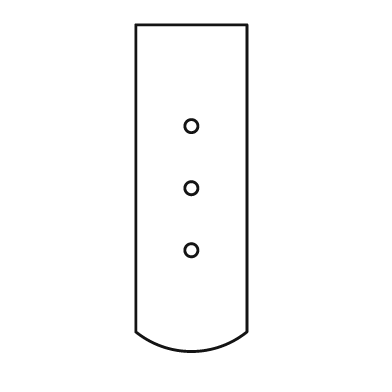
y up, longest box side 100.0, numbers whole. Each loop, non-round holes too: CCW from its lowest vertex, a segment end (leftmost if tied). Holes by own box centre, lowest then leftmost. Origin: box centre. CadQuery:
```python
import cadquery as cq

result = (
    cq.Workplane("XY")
    .moveTo(-17.0, -44.0)
    .threePointArc((0.0, -50.0), (17.0, -44.0))
    .lineTo(17.0, 50.0)
    .lineTo(-17.0, 50.0)
    .close()
    .moveTo(0.0, -19.0)
    .circle(2.0)
    .moveTo(0.0, 0.0)
    .circle(2.0)
    .moveTo(0.0, 19.0)
    .circle(2.0)
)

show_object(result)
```